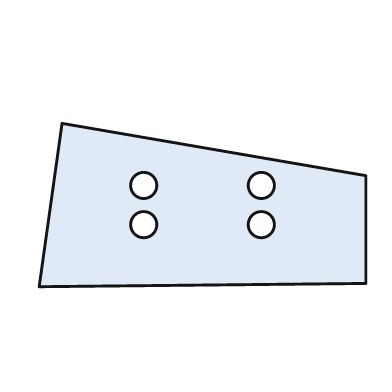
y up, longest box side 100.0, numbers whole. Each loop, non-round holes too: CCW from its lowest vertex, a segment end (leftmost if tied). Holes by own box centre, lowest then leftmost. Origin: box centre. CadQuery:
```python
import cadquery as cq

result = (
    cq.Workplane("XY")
    .moveTo(-50.0, -25.0)
    .lineTo(50.0, -24.0)
    .lineTo(50.0, 9.0)
    .lineTo(-43.0, 25.0)
    .close()
    .moveTo(-18.0, -6.0)
    .circle(4.0)
    .moveTo(18.0, -6.0)
    .circle(4.0)
    .moveTo(-18.0, 6.0)
    .circle(4.0)
    .moveTo(18.0, 6.0)
    .circle(4.0)
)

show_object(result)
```